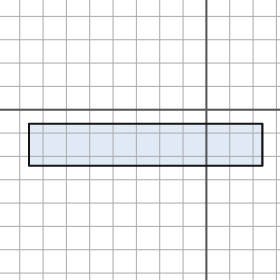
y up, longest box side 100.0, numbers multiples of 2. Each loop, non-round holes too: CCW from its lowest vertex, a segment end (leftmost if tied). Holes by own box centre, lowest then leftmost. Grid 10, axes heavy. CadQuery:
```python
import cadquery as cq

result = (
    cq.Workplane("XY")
    .moveTo(-76.0, -24.0)
    .lineTo(24.0, -24.0)
    .lineTo(24.0, -6.0)
    .lineTo(-76.0, -6.0)
    .close()
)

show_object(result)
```